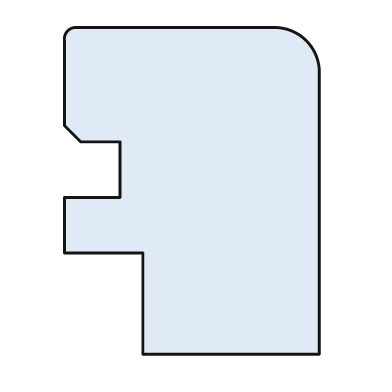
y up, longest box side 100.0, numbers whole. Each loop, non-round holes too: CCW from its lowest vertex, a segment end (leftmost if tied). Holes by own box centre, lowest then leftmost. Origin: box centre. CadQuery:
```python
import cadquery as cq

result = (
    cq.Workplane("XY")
    .moveTo(-15.0, -50.0)
    .lineTo(39.0, -50.0)
    .lineTo(39.0, 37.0)
    .threePointArc((35.0, 46.0), (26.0, 50.0))
    .lineTo(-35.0, 50.0)
    .threePointArc((-38.0, 49.0), (-39.0, 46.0))
    .lineTo(-39.0, 20.0)
    .lineTo(-34.0, 15.0)
    .lineTo(-22.0, 15.0)
    .lineTo(-22.0, -2.0)
    .lineTo(-39.0, -2.0)
    .lineTo(-39.0, -19.0)
    .lineTo(-15.0, -19.0)
    .close()
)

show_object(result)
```